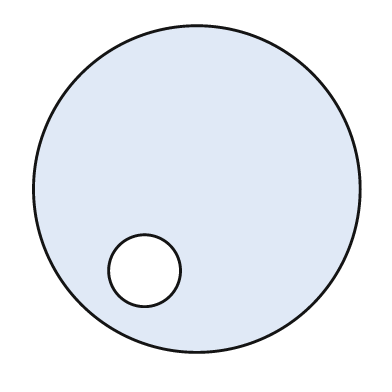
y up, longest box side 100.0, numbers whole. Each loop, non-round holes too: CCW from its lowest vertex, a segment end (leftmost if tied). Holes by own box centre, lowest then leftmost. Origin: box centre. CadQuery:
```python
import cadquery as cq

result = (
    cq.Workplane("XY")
    .moveTo(0.0, 0.0)
    .circle(50.0)
    .moveTo(-16.0, -25.0)
    .circle(11.0)
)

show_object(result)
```